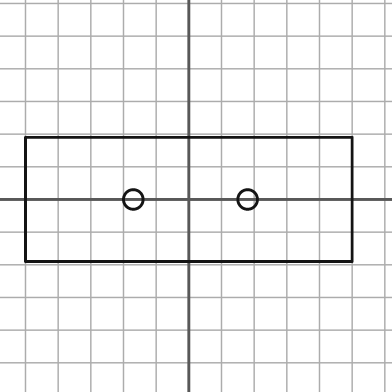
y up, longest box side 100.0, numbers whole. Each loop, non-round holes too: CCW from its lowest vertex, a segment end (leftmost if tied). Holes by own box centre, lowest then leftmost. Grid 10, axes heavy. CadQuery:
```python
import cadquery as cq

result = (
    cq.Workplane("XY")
    .moveTo(-50.0, -19.0)
    .lineTo(50.0, -19.0)
    .lineTo(50.0, 19.0)
    .lineTo(-50.0, 19.0)
    .close()
    .moveTo(-17.0, 0.0)
    .circle(3.0)
    .moveTo(18.0, 0.0)
    .circle(3.0)
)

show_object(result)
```